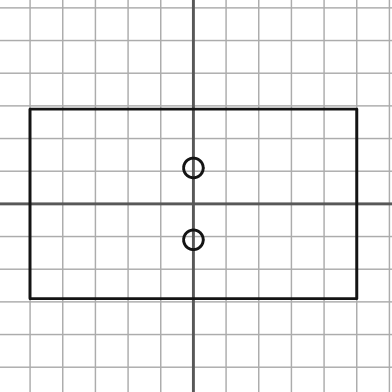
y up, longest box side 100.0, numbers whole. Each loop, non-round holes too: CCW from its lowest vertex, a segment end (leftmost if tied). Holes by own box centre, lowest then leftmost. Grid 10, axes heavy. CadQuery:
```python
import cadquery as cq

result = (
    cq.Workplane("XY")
    .moveTo(-50.0, -29.0)
    .lineTo(50.0, -29.0)
    .lineTo(50.0, 29.0)
    .lineTo(-50.0, 29.0)
    .close()
    .moveTo(0.0, -11.0)
    .circle(3.0)
    .moveTo(0.0, 11.0)
    .circle(3.0)
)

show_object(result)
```